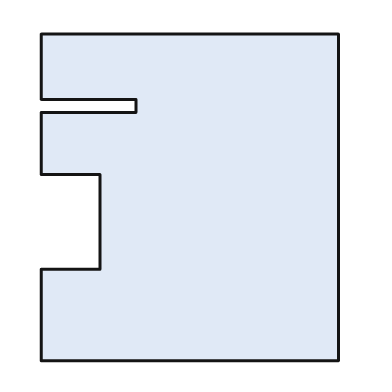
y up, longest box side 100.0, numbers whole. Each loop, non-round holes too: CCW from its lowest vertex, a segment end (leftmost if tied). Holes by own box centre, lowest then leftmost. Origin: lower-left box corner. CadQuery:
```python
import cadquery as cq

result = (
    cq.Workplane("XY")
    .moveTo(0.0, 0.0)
    .lineTo(91.0, 0.0)
    .lineTo(91.0, 100.0)
    .lineTo(0.0, 100.0)
    .lineTo(0.0, 80.0)
    .lineTo(29.0, 80.0)
    .lineTo(29.0, 76.0)
    .lineTo(0.0, 76.0)
    .lineTo(0.0, 57.0)
    .lineTo(18.0, 57.0)
    .lineTo(18.0, 28.0)
    .lineTo(0.0, 28.0)
    .close()
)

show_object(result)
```